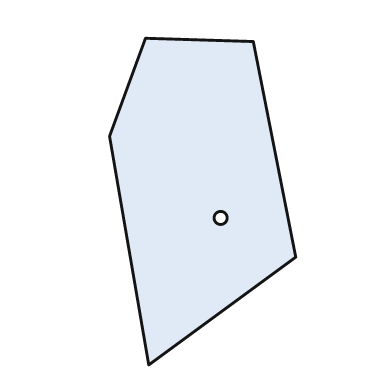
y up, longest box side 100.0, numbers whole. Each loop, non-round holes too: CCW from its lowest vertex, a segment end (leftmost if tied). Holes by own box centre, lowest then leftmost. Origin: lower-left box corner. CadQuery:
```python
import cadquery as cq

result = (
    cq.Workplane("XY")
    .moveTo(12.0, 0.0)
    .lineTo(57.0, 33.0)
    .lineTo(44.0, 99.0)
    .lineTo(11.0, 100.0)
    .lineTo(0.0, 70.0)
    .close()
    .moveTo(34.0, 45.0)
    .circle(2.0)
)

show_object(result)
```